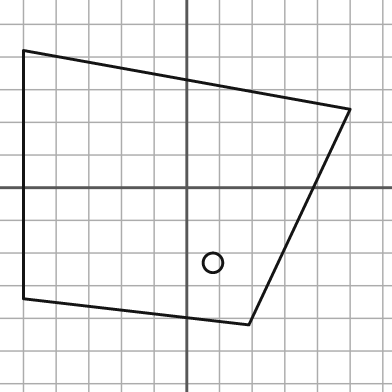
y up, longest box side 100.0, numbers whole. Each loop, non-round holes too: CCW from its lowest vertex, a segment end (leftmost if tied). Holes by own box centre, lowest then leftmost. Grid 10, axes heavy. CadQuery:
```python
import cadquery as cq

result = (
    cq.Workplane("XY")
    .moveTo(19.0, -42.0)
    .lineTo(50.0, 24.0)
    .lineTo(-50.0, 42.0)
    .lineTo(-50.0, -34.0)
    .close()
    .moveTo(8.0, -23.0)
    .circle(3.0)
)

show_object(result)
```